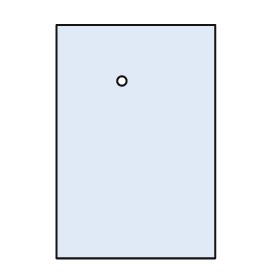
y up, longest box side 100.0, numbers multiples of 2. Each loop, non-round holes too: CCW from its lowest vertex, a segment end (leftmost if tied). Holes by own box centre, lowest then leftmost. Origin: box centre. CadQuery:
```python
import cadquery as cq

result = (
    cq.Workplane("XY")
    .moveTo(-34.0, -50.0)
    .lineTo(34.0, -50.0)
    .lineTo(34.0, 50.0)
    .lineTo(-34.0, 50.0)
    .close()
    .moveTo(-6.0, 26.0)
    .circle(2.0)
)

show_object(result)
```